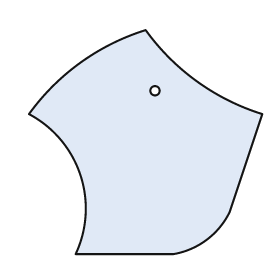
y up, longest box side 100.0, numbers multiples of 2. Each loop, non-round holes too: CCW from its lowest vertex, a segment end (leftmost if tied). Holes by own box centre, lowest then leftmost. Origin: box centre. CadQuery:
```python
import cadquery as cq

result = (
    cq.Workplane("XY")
    .moveTo(-30.0, -48.0)
    .lineTo(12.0, -48.0)
    .threePointArc((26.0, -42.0), (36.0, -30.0))
    .lineTo(50.0, 12.0)
    .threePointArc((22.0, 26.0), (0.0, 48.0))
    .threePointArc((-28.0, 34.0), (-50.0, 12.0))
    .threePointArc((-28.0, -14.0), (-30.0, -48.0))
    .close()
    .moveTo(4.0, 22.0)
    .circle(2.0)
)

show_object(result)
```